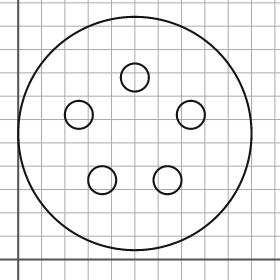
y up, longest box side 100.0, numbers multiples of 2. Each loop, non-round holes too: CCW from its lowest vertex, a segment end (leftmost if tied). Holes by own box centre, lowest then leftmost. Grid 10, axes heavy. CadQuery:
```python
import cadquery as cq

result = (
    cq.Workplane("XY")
    .moveTo(50.0, 54.0)
    .circle(50.0)
    .moveTo(36.0, 34.0)
    .circle(6.0)
    .moveTo(64.0, 34.0)
    .circle(6.0)
    .moveTo(26.0, 62.0)
    .circle(6.0)
    .moveTo(74.0, 62.0)
    .circle(6.0)
    .moveTo(50.0, 78.0)
    .circle(6.0)
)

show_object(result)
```